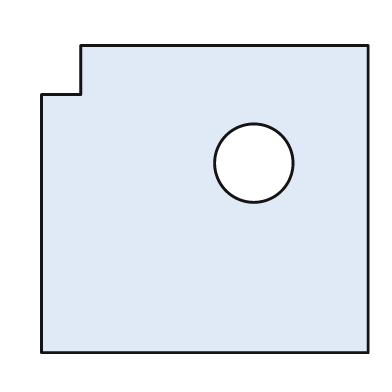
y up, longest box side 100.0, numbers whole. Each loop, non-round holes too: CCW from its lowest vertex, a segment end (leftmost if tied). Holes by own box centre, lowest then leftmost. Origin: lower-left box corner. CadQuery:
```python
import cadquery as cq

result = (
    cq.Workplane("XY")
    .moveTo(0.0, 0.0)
    .lineTo(100.0, 0.0)
    .lineTo(100.0, 94.0)
    .lineTo(12.0, 94.0)
    .lineTo(12.0, 79.0)
    .lineTo(0.0, 79.0)
    .close()
    .moveTo(65.0, 58.0)
    .circle(12.0)
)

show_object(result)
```